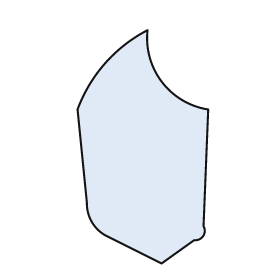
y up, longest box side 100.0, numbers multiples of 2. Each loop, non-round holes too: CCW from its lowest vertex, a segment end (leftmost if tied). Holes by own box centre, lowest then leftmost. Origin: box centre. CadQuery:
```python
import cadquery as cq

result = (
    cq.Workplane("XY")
    .moveTo(8.0, -50.0)
    .lineTo(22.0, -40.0)
    .threePointArc((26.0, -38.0), (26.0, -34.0))
    .lineTo(28.0, 16.0)
    .threePointArc((8.0, 28.0), (2.0, 50.0))
    .threePointArc((-16.0, 36.0), (-28.0, 16.0))
    .lineTo(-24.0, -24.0)
    .threePointArc((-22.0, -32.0), (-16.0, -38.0))
    .close()
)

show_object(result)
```